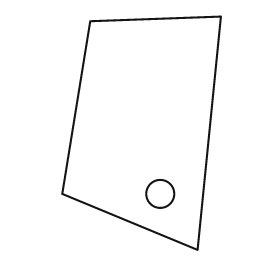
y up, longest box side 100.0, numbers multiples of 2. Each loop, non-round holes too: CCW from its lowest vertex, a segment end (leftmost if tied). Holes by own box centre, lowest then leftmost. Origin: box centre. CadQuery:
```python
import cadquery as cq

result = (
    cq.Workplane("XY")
    .moveTo(24.0, -50.0)
    .lineTo(34.0, 50.0)
    .lineTo(-22.0, 48.0)
    .lineTo(-34.0, -26.0)
    .close()
    .moveTo(8.0, -26.0)
    .circle(6.0)
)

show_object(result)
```